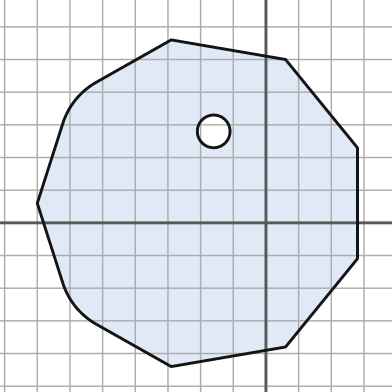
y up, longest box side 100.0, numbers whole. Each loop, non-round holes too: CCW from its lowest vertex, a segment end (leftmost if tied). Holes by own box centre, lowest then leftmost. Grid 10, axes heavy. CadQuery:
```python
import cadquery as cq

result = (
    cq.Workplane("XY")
    .moveTo(-29.0, -44.0)
    .lineTo(6.0, -38.0)
    .lineTo(28.0, -11.0)
    .lineTo(28.0, 23.0)
    .lineTo(6.0, 50.0)
    .lineTo(-29.0, 56.0)
    .lineTo(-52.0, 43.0)
    .threePointArc((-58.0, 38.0), (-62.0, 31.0))
    .lineTo(-70.0, 6.0)
    .lineTo(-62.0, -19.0)
    .threePointArc((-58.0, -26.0), (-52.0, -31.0))
    .close()
    .moveTo(-16.0, 28.0)
    .circle(5.0)
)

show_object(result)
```